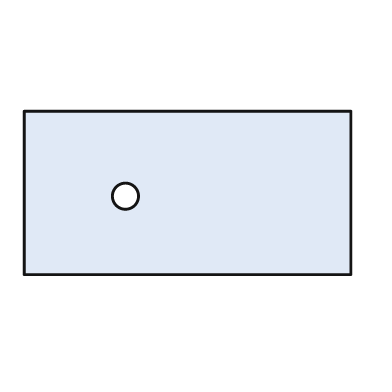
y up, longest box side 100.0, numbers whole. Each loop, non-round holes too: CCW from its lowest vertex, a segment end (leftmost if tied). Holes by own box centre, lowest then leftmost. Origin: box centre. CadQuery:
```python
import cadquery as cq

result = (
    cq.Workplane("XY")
    .moveTo(-50.0, -25.0)
    .lineTo(50.0, -25.0)
    .lineTo(50.0, 25.0)
    .lineTo(-50.0, 25.0)
    .close()
    .moveTo(-19.0, -1.0)
    .circle(4.0)
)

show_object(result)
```